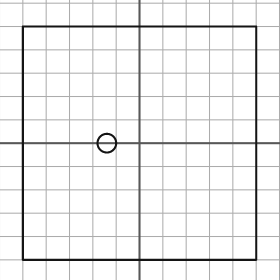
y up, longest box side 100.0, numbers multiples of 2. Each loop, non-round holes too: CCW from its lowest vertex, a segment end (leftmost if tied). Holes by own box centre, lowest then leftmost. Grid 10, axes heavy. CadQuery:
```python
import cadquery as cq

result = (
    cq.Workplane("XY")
    .moveTo(-50.0, -50.0)
    .lineTo(50.0, -50.0)
    .lineTo(50.0, 50.0)
    .lineTo(-50.0, 50.0)
    .close()
    .moveTo(-14.0, 0.0)
    .circle(4.0)
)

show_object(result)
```